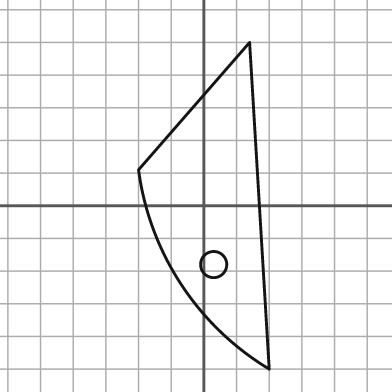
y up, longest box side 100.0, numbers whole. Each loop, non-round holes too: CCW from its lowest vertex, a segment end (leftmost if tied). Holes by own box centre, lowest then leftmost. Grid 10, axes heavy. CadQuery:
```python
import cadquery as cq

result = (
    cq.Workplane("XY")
    .moveTo(20.0, -50.0)
    .lineTo(14.0, 50.0)
    .lineTo(-20.0, 11.0)
    .threePointArc((-7.0, -24.0), (20.0, -50.0))
    .close()
    .moveTo(3.0, -18.0)
    .circle(4.0)
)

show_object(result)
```